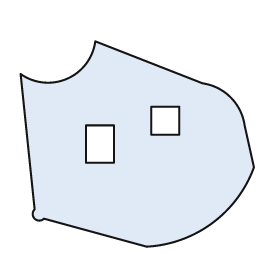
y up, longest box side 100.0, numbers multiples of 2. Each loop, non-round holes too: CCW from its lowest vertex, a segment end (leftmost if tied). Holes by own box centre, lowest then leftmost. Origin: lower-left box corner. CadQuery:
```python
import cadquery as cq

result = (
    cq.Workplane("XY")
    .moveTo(54.0, 0.0)
    .threePointArc((82.0, 10.0), (100.0, 34.0))
    .lineTo(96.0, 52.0)
    .threePointArc((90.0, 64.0), (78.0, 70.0))
    .lineTo(32.0, 88.0)
    .threePointArc((20.0, 72.0), (0.0, 74.0))
    .lineTo(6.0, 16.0)
    .threePointArc((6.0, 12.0), (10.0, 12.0))
    .close()
    .moveTo(28.0, 36.0)
    .lineTo(40.0, 36.0)
    .lineTo(40.0, 52.0)
    .lineTo(28.0, 52.0)
    .close()
    .moveTo(56.0, 48.0)
    .lineTo(68.0, 48.0)
    .lineTo(68.0, 60.0)
    .lineTo(56.0, 60.0)
    .close()
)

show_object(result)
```